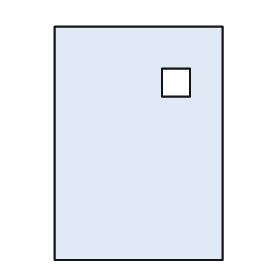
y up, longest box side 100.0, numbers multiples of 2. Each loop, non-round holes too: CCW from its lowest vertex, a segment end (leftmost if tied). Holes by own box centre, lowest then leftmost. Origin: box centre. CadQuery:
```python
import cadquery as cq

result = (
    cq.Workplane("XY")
    .moveTo(-36.0, -50.0)
    .lineTo(36.0, -50.0)
    .lineTo(36.0, 50.0)
    .lineTo(-36.0, 50.0)
    .close()
    .moveTo(10.0, 20.0)
    .lineTo(22.0, 20.0)
    .lineTo(22.0, 32.0)
    .lineTo(10.0, 32.0)
    .close()
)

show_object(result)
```